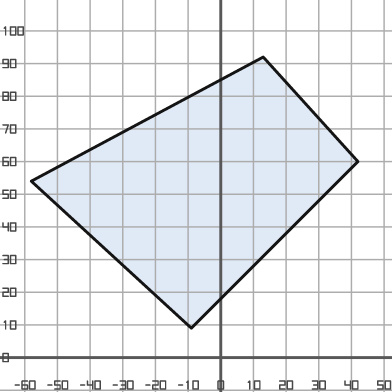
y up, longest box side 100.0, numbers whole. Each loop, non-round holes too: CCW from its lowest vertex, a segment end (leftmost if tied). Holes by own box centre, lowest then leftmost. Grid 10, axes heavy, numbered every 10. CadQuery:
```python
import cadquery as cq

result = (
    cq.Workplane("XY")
    .moveTo(-9.0, 9.0)
    .lineTo(42.0, 60.0)
    .lineTo(13.0, 92.0)
    .lineTo(-58.0, 54.0)
    .close()
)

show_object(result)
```